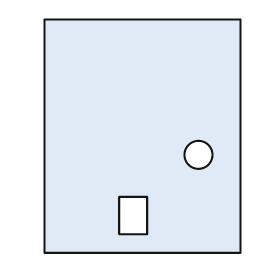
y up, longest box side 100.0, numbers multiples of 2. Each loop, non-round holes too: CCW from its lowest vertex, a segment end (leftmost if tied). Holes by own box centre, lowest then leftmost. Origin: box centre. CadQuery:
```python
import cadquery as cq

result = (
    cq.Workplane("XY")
    .moveTo(-42.0, -50.0)
    .lineTo(42.0, -50.0)
    .lineTo(42.0, 50.0)
    .lineTo(-42.0, 50.0)
    .close()
    .moveTo(-10.0, -42.0)
    .lineTo(2.0, -42.0)
    .lineTo(2.0, -26.0)
    .lineTo(-10.0, -26.0)
    .close()
    .moveTo(24.0, -8.0)
    .circle(6.0)
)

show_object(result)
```